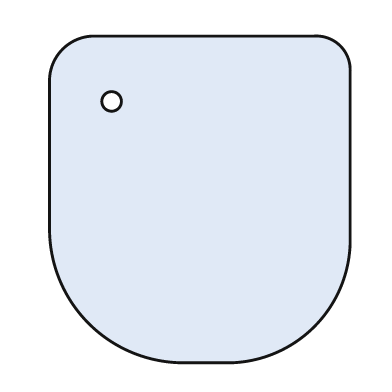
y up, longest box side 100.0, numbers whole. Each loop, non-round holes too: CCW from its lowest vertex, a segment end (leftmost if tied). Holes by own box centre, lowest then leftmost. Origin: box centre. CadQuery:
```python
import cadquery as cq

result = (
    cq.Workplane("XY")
    .moveTo(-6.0, -50.0)
    .lineTo(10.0, -50.0)
    .threePointArc((35.0, -39.0), (46.0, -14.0))
    .lineTo(46.0, 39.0)
    .threePointArc((43.0, 47.0), (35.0, 50.0))
    .lineTo(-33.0, 50.0)
    .threePointArc((-42.0, 46.0), (-46.0, 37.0))
    .lineTo(-46.0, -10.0)
    .threePointArc((-34.0, -38.0), (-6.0, -50.0))
    .close()
    .moveTo(-27.0, 30.0)
    .circle(3.0)
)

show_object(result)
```